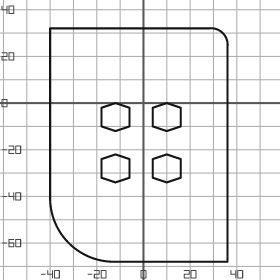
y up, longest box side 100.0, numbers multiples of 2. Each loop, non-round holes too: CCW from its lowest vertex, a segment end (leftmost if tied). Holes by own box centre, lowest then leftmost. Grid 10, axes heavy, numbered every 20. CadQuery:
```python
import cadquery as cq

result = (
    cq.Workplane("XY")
    .moveTo(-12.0, -68.0)
    .lineTo(36.0, -68.0)
    .lineTo(36.0, 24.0)
    .threePointArc((34.0, 30.0), (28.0, 32.0))
    .lineTo(-40.0, 32.0)
    .lineTo(-40.0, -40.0)
    .threePointArc((-32.0, -60.0), (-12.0, -68.0))
    .close()
    .moveTo(-12.0, -34.0)
    .lineTo(-6.0, -32.0)
    .lineTo(-6.0, -24.0)
    .lineTo(-12.0, -22.0)
    .lineTo(-18.0, -24.0)
    .lineTo(-18.0, -32.0)
    .close()
    .moveTo(10.0, -34.0)
    .lineTo(16.0, -32.0)
    .lineTo(16.0, -24.0)
    .lineTo(10.0, -22.0)
    .lineTo(4.0, -24.0)
    .lineTo(4.0, -32.0)
    .close()
    .moveTo(-12.0, -12.0)
    .lineTo(-6.0, -10.0)
    .lineTo(-6.0, -2.0)
    .lineTo(-12.0, 0.0)
    .lineTo(-18.0, -2.0)
    .lineTo(-18.0, -10.0)
    .close()
    .moveTo(10.0, -12.0)
    .lineTo(16.0, -10.0)
    .lineTo(16.0, -2.0)
    .lineTo(10.0, 0.0)
    .lineTo(4.0, -2.0)
    .lineTo(4.0, -10.0)
    .close()
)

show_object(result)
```